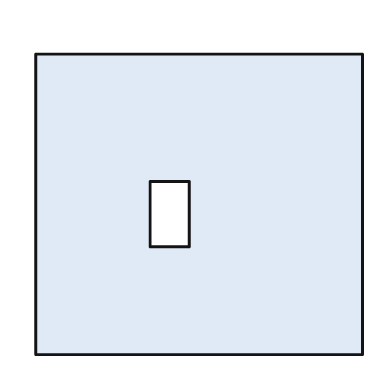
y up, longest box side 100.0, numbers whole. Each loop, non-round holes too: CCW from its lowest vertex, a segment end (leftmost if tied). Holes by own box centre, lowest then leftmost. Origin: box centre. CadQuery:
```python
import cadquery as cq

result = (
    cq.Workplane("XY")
    .moveTo(-50.0, -46.0)
    .lineTo(50.0, -46.0)
    .lineTo(50.0, 46.0)
    .lineTo(-50.0, 46.0)
    .close()
    .moveTo(-15.0, -13.0)
    .lineTo(-3.0, -13.0)
    .lineTo(-3.0, 7.0)
    .lineTo(-15.0, 7.0)
    .close()
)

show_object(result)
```